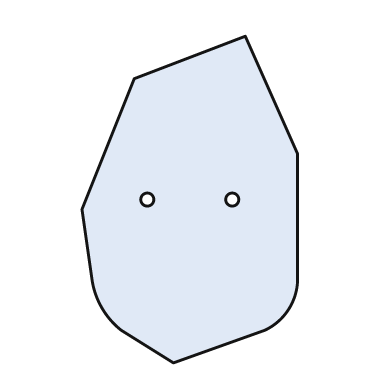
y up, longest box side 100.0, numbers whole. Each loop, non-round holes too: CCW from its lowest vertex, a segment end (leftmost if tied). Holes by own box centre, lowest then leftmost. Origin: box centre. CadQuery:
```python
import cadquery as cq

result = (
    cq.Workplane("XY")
    .moveTo(-5.0, -50.0)
    .lineTo(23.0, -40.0)
    .threePointArc((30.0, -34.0), (33.0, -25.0))
    .lineTo(33.0, 14.0)
    .lineTo(17.0, 50.0)
    .lineTo(-17.0, 37.0)
    .lineTo(-33.0, -3.0)
    .lineTo(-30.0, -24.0)
    .threePointArc((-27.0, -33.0), (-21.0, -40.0))
    .close()
    .moveTo(-13.0, 0.0)
    .circle(2.0)
    .moveTo(13.0, 0.0)
    .circle(2.0)
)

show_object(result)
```